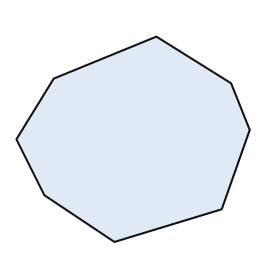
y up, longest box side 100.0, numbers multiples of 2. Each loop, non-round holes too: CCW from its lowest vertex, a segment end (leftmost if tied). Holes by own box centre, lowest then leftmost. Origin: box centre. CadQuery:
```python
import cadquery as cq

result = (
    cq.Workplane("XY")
    .moveTo(-8.0, -44.0)
    .lineTo(38.0, -30.0)
    .lineTo(50.0, 4.0)
    .lineTo(42.0, 24.0)
    .lineTo(10.0, 44.0)
    .lineTo(-34.0, 26.0)
    .lineTo(-50.0, 0.0)
    .lineTo(-38.0, -24.0)
    .close()
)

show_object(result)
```